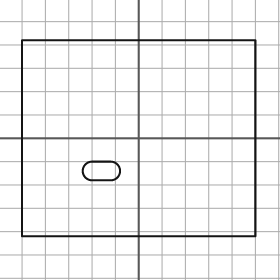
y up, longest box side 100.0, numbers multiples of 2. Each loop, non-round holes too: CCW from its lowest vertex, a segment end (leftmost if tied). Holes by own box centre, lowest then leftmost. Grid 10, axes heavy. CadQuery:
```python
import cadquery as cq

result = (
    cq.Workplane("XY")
    .moveTo(-50.0, -42.0)
    .lineTo(50.0, -42.0)
    .lineTo(50.0, 42.0)
    .lineTo(-50.0, 42.0)
    .close()
    .moveTo(-20.0, -18.0)
    .lineTo(-12.0, -18.0)
    .threePointArc((-8.0, -14.0), (-12.0, -10.0))
    .lineTo(-20.0, -10.0)
    .threePointArc((-24.0, -14.0), (-20.0, -18.0))
    .close()
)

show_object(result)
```